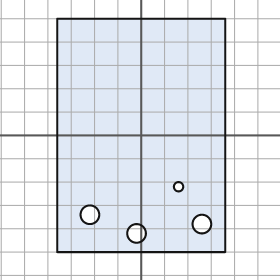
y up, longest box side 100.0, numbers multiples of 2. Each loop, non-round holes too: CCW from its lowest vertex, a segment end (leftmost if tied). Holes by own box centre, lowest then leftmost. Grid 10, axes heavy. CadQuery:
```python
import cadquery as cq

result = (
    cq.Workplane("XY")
    .moveTo(-36.0, -50.0)
    .lineTo(36.0, -50.0)
    .lineTo(36.0, 50.0)
    .lineTo(-36.0, 50.0)
    .close()
    .moveTo(-2.0, -42.0)
    .circle(4.0)
    .moveTo(26.0, -38.0)
    .circle(4.0)
    .moveTo(-22.0, -34.0)
    .circle(4.0)
    .moveTo(16.0, -22.0)
    .circle(2.0)
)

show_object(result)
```